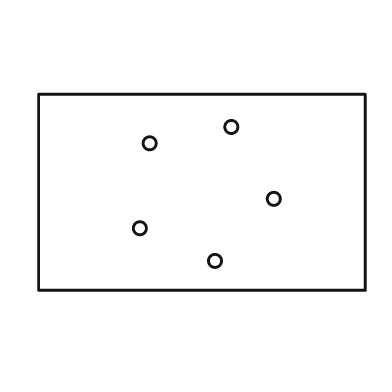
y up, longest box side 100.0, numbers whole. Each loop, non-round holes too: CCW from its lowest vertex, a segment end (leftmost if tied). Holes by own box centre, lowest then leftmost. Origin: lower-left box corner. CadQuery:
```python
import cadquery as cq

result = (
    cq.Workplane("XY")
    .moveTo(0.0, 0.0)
    .lineTo(100.0, 0.0)
    .lineTo(100.0, 60.0)
    .lineTo(0.0, 60.0)
    .close()
    .moveTo(54.0, 9.0)
    .circle(2.0)
    .moveTo(31.0, 19.0)
    .circle(2.0)
    .moveTo(72.0, 28.0)
    .circle(2.0)
    .moveTo(34.0, 45.0)
    .circle(2.0)
    .moveTo(59.0, 50.0)
    .circle(2.0)
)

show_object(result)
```